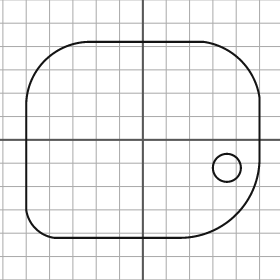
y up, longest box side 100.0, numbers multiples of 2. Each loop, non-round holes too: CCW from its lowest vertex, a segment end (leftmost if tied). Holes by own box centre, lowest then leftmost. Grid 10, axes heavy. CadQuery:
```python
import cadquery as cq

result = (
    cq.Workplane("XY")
    .moveTo(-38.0, -42.0)
    .lineTo(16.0, -42.0)
    .threePointArc((40.0, -32.0), (50.0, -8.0))
    .lineTo(50.0, 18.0)
    .threePointArc((42.0, 34.0), (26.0, 42.0))
    .lineTo(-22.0, 42.0)
    .threePointArc((-42.0, 34.0), (-50.0, 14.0))
    .lineTo(-50.0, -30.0)
    .threePointArc((-46.0, -38.0), (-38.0, -42.0))
    .close()
    .moveTo(36.0, -12.0)
    .circle(6.0)
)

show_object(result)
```